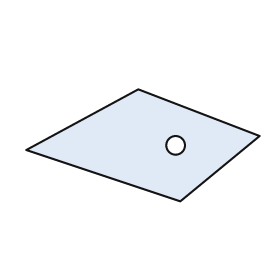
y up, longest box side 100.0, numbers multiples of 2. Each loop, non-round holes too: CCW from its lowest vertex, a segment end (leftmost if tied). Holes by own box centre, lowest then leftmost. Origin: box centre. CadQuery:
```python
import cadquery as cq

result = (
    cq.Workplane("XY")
    .moveTo(16.0, -24.0)
    .lineTo(50.0, 4.0)
    .lineTo(-2.0, 24.0)
    .lineTo(-50.0, -2.0)
    .close()
    .moveTo(14.0, 0.0)
    .circle(4.0)
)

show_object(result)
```